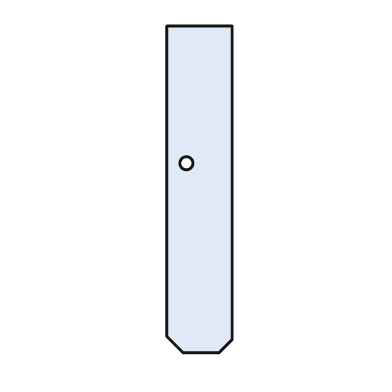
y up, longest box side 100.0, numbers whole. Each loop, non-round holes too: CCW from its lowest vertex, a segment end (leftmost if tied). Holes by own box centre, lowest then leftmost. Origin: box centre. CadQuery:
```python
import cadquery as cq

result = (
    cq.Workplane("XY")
    .moveTo(-5.0, -50.0)
    .lineTo(6.0, -50.0)
    .lineTo(10.0, -46.0)
    .lineTo(10.0, 50.0)
    .lineTo(-10.0, 50.0)
    .lineTo(-10.0, -45.0)
    .close()
    .moveTo(-4.0, 8.0)
    .circle(2.0)
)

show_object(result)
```